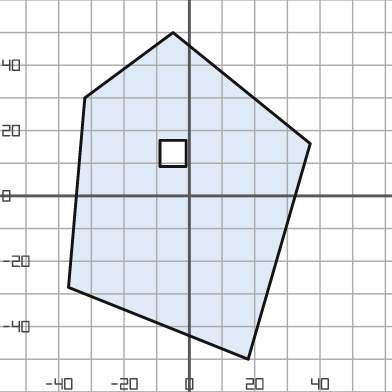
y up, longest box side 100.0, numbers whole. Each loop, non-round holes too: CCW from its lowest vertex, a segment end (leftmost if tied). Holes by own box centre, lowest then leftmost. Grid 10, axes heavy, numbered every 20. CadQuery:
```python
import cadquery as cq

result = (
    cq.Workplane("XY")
    .moveTo(18.0, -50.0)
    .lineTo(37.0, 16.0)
    .lineTo(-5.0, 50.0)
    .lineTo(-32.0, 30.0)
    .lineTo(-37.0, -28.0)
    .close()
    .moveTo(-9.0, 9.0)
    .lineTo(-1.0, 9.0)
    .lineTo(-1.0, 17.0)
    .lineTo(-9.0, 17.0)
    .close()
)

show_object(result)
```